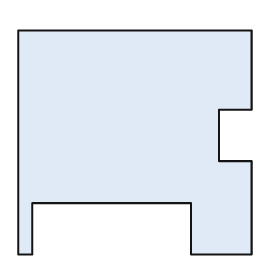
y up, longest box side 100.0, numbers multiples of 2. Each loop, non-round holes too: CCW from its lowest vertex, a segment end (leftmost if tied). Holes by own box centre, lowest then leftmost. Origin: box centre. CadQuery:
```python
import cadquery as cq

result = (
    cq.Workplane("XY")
    .moveTo(-50.0, -48.0)
    .lineTo(-44.0, -48.0)
    .lineTo(-44.0, -26.0)
    .lineTo(24.0, -26.0)
    .lineTo(24.0, -48.0)
    .lineTo(50.0, -48.0)
    .lineTo(50.0, -8.0)
    .lineTo(36.0, -8.0)
    .lineTo(36.0, 14.0)
    .lineTo(50.0, 14.0)
    .lineTo(50.0, 48.0)
    .lineTo(-50.0, 48.0)
    .close()
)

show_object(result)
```